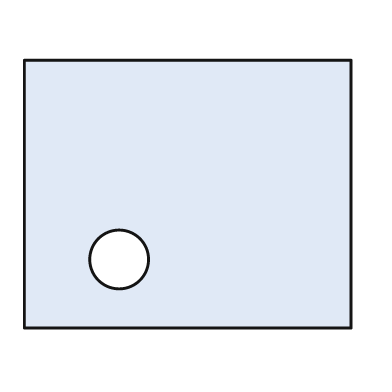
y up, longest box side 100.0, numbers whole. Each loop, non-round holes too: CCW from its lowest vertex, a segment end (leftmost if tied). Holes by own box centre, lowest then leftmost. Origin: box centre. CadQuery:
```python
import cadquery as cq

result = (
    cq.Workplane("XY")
    .moveTo(-50.0, -41.0)
    .lineTo(50.0, -41.0)
    .lineTo(50.0, 41.0)
    .lineTo(-50.0, 41.0)
    .close()
    .moveTo(-21.0, -20.0)
    .circle(9.0)
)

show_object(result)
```